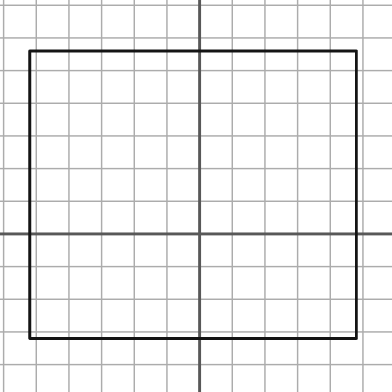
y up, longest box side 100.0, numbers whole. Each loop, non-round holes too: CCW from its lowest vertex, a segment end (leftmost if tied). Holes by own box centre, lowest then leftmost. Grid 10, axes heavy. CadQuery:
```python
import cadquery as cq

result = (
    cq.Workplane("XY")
    .moveTo(-52.0, -32.0)
    .lineTo(48.0, -32.0)
    .lineTo(48.0, 56.0)
    .lineTo(-52.0, 56.0)
    .close()
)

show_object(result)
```